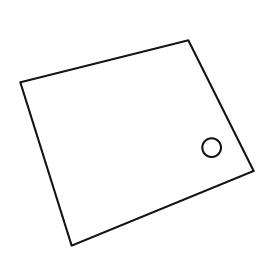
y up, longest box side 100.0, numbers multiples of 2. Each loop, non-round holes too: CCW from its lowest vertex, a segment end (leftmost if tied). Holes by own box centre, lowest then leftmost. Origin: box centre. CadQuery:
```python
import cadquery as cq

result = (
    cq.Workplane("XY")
    .moveTo(-28.0, -44.0)
    .lineTo(50.0, -12.0)
    .lineTo(22.0, 44.0)
    .lineTo(-50.0, 26.0)
    .close()
    .moveTo(32.0, -2.0)
    .circle(4.0)
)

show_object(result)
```